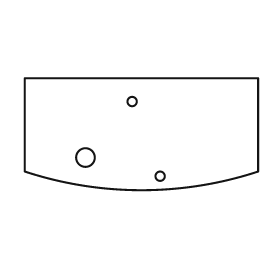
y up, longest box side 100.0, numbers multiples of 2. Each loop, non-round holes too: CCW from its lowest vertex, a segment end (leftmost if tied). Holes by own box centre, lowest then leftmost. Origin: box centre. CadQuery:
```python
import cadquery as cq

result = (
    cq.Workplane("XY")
    .moveTo(-50.0, -16.0)
    .threePointArc((0.0, -24.0), (50.0, -16.0))
    .lineTo(50.0, 24.0)
    .lineTo(-50.0, 24.0)
    .close()
    .moveTo(8.0, -18.0)
    .circle(2.0)
    .moveTo(-24.0, -10.0)
    .circle(4.0)
    .moveTo(-4.0, 14.0)
    .circle(2.0)
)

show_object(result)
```